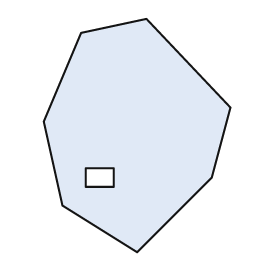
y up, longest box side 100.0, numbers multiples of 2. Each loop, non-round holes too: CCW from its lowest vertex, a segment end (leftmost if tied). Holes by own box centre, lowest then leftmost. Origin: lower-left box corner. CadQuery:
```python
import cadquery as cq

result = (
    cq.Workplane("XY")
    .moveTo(40.0, 0.0)
    .lineTo(72.0, 32.0)
    .lineTo(80.0, 62.0)
    .lineTo(44.0, 100.0)
    .lineTo(16.0, 94.0)
    .lineTo(0.0, 56.0)
    .lineTo(8.0, 20.0)
    .close()
    .moveTo(18.0, 28.0)
    .lineTo(30.0, 28.0)
    .lineTo(30.0, 36.0)
    .lineTo(18.0, 36.0)
    .close()
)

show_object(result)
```